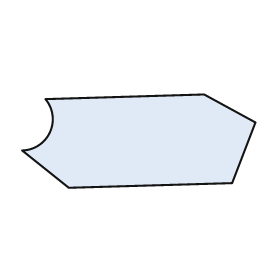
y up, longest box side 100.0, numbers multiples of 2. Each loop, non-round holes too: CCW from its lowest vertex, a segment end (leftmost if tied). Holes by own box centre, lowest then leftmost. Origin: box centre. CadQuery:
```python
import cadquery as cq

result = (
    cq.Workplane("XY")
    .moveTo(-30.0, -20.0)
    .lineTo(40.0, -18.0)
    .lineTo(50.0, 8.0)
    .lineTo(28.0, 20.0)
    .lineTo(-40.0, 18.0)
    .threePointArc((-38.0, 4.0), (-50.0, -4.0))
    .close()
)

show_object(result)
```